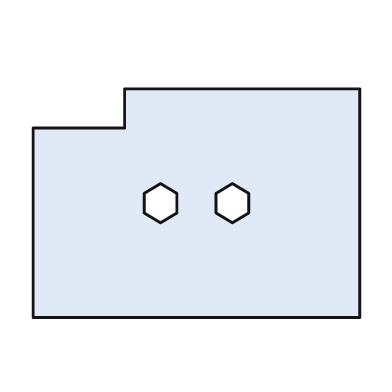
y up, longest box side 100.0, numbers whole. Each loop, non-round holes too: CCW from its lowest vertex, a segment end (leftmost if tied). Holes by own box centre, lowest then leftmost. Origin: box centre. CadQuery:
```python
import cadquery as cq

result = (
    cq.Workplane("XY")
    .moveTo(-50.0, -35.0)
    .lineTo(50.0, -35.0)
    .lineTo(50.0, 35.0)
    .lineTo(-22.0, 35.0)
    .lineTo(-22.0, 23.0)
    .lineTo(-50.0, 23.0)
    .close()
    .moveTo(-11.0, -6.0)
    .lineTo(-6.0, -3.0)
    .lineTo(-6.0, 3.0)
    .lineTo(-11.0, 6.0)
    .lineTo(-16.0, 3.0)
    .lineTo(-16.0, -3.0)
    .close()
    .moveTo(11.0, -6.0)
    .lineTo(16.0, -3.0)
    .lineTo(16.0, 3.0)
    .lineTo(11.0, 6.0)
    .lineTo(6.0, 3.0)
    .lineTo(6.0, -3.0)
    .close()
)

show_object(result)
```